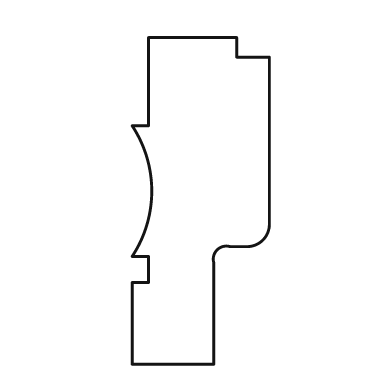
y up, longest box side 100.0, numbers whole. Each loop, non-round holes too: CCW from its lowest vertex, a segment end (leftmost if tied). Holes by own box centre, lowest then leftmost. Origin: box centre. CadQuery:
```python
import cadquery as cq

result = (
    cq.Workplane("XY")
    .moveTo(-21.0, -50.0)
    .lineTo(4.0, -50.0)
    .lineTo(4.0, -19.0)
    .threePointArc((5.0, -15.0), (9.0, -14.0))
    .lineTo(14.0, -14.0)
    .threePointArc((19.0, -12.0), (21.0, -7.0))
    .lineTo(21.0, 44.0)
    .lineTo(11.0, 44.0)
    .lineTo(11.0, 50.0)
    .lineTo(-16.0, 50.0)
    .lineTo(-16.0, 23.0)
    .lineTo(-21.0, 23.0)
    .threePointArc((-15.0, 3.0), (-21.0, -17.0))
    .lineTo(-16.0, -17.0)
    .lineTo(-16.0, -25.0)
    .lineTo(-21.0, -25.0)
    .close()
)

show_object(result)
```